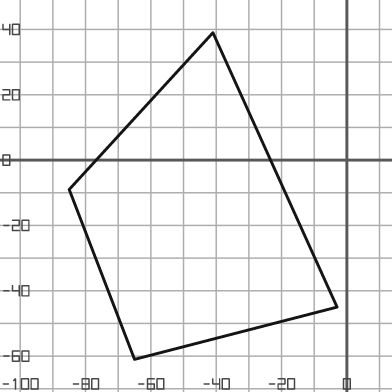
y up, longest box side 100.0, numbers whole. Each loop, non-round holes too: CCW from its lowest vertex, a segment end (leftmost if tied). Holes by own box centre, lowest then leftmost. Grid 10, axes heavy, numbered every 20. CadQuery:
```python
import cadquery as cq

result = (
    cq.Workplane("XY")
    .moveTo(-65.0, -61.0)
    .lineTo(-3.0, -45.0)
    .lineTo(-41.0, 39.0)
    .lineTo(-85.0, -9.0)
    .close()
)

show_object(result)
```